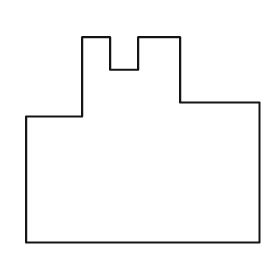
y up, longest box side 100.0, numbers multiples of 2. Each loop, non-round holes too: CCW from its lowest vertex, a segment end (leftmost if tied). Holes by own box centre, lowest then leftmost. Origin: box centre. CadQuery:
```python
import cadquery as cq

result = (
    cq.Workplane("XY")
    .moveTo(-50.0, -44.0)
    .lineTo(50.0, -44.0)
    .lineTo(50.0, 16.0)
    .lineTo(16.0, 16.0)
    .lineTo(16.0, 44.0)
    .lineTo(-2.0, 44.0)
    .lineTo(-2.0, 30.0)
    .lineTo(-14.0, 30.0)
    .lineTo(-14.0, 44.0)
    .lineTo(-26.0, 44.0)
    .lineTo(-26.0, 10.0)
    .lineTo(-50.0, 10.0)
    .close()
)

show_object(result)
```